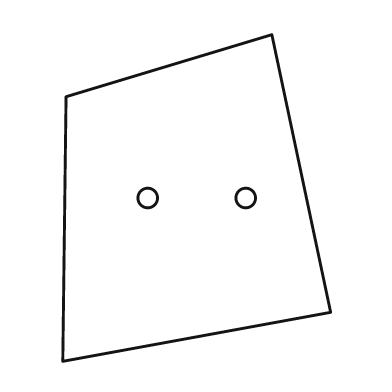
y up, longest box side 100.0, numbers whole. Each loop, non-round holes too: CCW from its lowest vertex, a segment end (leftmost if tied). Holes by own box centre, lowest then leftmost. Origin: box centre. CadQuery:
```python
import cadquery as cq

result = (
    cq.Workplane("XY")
    .moveTo(-41.0, -50.0)
    .lineTo(41.0, -35.0)
    .lineTo(23.0, 50.0)
    .lineTo(-40.0, 31.0)
    .close()
    .moveTo(-15.0, 0.0)
    .circle(3.0)
    .moveTo(15.0, 0.0)
    .circle(3.0)
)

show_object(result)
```